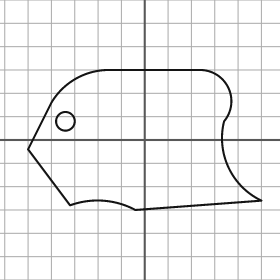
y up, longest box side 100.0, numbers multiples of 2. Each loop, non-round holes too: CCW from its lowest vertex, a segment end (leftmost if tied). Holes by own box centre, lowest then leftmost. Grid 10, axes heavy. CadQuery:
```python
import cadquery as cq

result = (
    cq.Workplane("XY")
    .moveTo(-4.0, -30.0)
    .lineTo(50.0, -26.0)
    .threePointArc((36.0, -12.0), (34.0, 8.0))
    .threePointArc((36.0, 22.0), (24.0, 30.0))
    .lineTo(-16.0, 30.0)
    .threePointArc((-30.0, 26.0), (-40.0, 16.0))
    .lineTo(-50.0, -4.0)
    .lineTo(-32.0, -28.0)
    .threePointArc((-18.0, -26.0), (-4.0, -30.0))
    .close()
    .moveTo(-34.0, 8.0)
    .circle(4.0)
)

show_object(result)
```